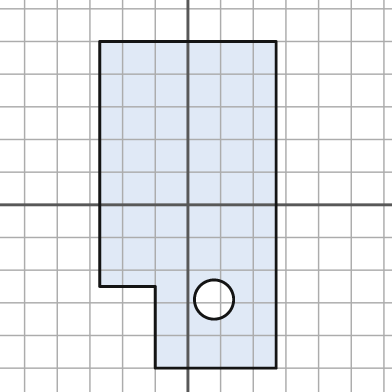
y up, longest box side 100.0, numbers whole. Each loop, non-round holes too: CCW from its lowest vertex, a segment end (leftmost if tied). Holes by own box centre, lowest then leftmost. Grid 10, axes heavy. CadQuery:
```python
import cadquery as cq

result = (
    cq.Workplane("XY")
    .moveTo(-10.0, -50.0)
    .lineTo(27.0, -50.0)
    .lineTo(27.0, 50.0)
    .lineTo(-27.0, 50.0)
    .lineTo(-27.0, -25.0)
    .lineTo(-10.0, -25.0)
    .close()
    .moveTo(8.0, -29.0)
    .circle(6.0)
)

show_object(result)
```